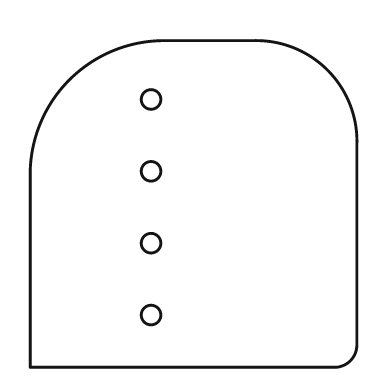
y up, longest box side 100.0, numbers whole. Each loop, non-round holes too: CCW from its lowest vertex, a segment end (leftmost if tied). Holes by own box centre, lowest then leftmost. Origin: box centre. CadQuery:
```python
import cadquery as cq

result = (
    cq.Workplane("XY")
    .moveTo(-50.0, -50.0)
    .lineTo(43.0, -50.0)
    .threePointArc((48.0, -48.0), (50.0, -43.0))
    .lineTo(50.0, 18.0)
    .threePointArc((41.0, 41.0), (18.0, 50.0))
    .lineTo(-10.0, 50.0)
    .threePointArc((-38.0, 38.0), (-50.0, 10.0))
    .close()
    .moveTo(-13.0, -34.0)
    .circle(3.0)
    .moveTo(-13.0, -12.0)
    .circle(3.0)
    .moveTo(-13.0, 10.0)
    .circle(3.0)
    .moveTo(-13.0, 32.0)
    .circle(3.0)
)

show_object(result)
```